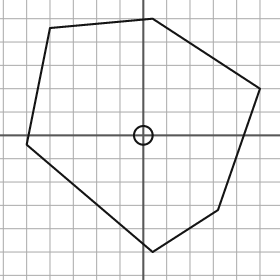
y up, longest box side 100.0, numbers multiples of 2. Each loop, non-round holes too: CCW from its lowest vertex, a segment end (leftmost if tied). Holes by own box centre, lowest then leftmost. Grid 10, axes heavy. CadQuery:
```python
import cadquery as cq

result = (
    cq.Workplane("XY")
    .moveTo(4.0, -50.0)
    .lineTo(32.0, -32.0)
    .lineTo(50.0, 20.0)
    .lineTo(4.0, 50.0)
    .lineTo(-40.0, 46.0)
    .lineTo(-50.0, -4.0)
    .close()
    .moveTo(0.0, 0.0)
    .circle(4.0)
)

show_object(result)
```